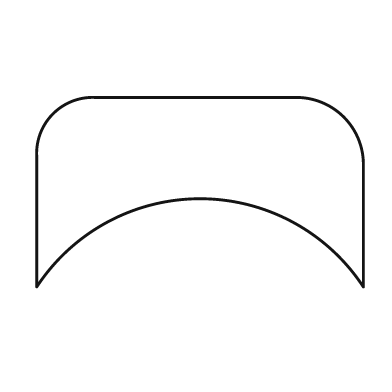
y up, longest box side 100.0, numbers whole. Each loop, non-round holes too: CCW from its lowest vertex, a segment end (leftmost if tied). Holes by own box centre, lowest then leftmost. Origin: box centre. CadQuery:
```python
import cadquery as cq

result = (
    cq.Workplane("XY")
    .moveTo(-50.0, -29.0)
    .threePointArc((0.0, -2.0), (50.0, -29.0))
    .lineTo(50.0, 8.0)
    .threePointArc((44.0, 23.0), (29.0, 29.0))
    .lineTo(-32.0, 29.0)
    .threePointArc((-45.0, 24.0), (-50.0, 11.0))
    .close()
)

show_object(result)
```